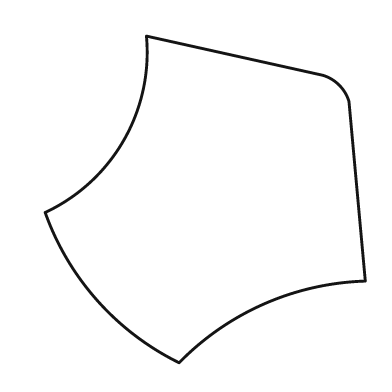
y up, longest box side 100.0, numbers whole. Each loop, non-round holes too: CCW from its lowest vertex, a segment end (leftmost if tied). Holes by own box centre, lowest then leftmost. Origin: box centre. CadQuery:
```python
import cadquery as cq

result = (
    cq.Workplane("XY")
    .moveTo(-8.0, -50.0)
    .threePointArc((18.0, -32.0), (49.0, -25.0))
    .lineTo(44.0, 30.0)
    .threePointArc((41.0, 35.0), (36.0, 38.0))
    .lineTo(-18.0, 50.0)
    .threePointArc((-25.0, 18.0), (-49.0, -4.0))
    .threePointArc((-33.0, -31.0), (-8.0, -50.0))
    .close()
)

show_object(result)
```